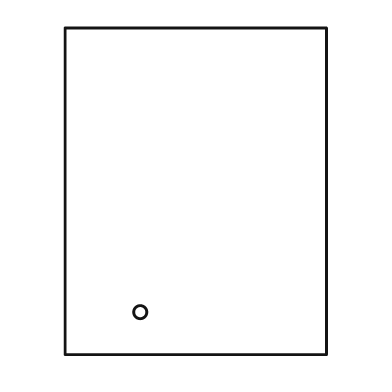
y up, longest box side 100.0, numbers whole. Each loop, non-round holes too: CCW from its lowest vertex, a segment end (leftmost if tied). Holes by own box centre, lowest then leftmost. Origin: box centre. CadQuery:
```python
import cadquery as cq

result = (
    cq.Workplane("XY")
    .moveTo(-40.0, -50.0)
    .lineTo(40.0, -50.0)
    .lineTo(40.0, 50.0)
    .lineTo(-40.0, 50.0)
    .close()
    .moveTo(-17.0, -37.0)
    .circle(2.0)
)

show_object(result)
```